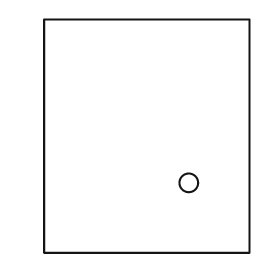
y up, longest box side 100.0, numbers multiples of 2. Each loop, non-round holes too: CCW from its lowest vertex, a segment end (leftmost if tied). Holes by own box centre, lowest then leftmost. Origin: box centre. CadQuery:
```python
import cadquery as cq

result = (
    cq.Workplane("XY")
    .moveTo(-44.0, -50.0)
    .lineTo(44.0, -50.0)
    .lineTo(44.0, 50.0)
    .lineTo(-44.0, 50.0)
    .close()
    .moveTo(18.0, -20.0)
    .circle(4.0)
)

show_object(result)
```